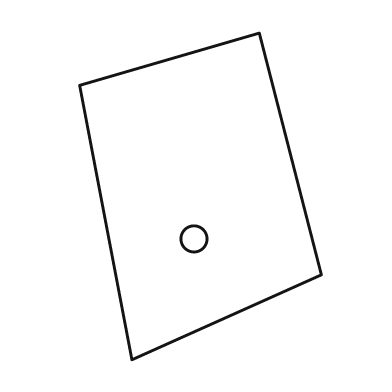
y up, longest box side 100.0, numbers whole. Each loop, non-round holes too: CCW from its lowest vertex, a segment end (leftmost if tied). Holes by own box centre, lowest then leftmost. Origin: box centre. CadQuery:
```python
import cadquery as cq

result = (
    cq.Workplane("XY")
    .moveTo(-21.0, -50.0)
    .lineTo(37.0, -24.0)
    .lineTo(18.0, 50.0)
    .lineTo(-37.0, 34.0)
    .close()
    .moveTo(-2.0, -13.0)
    .circle(4.0)
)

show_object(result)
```